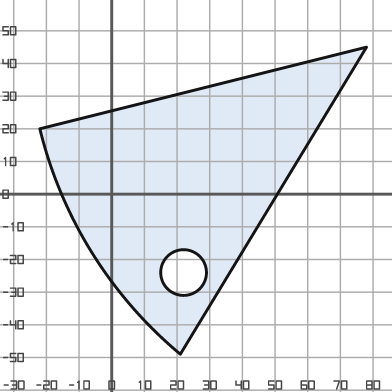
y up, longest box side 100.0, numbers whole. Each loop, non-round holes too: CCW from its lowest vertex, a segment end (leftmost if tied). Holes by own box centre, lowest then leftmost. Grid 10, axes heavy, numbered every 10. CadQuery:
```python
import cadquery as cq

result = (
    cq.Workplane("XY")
    .moveTo(21.0, -49.0)
    .lineTo(78.0, 45.0)
    .lineTo(-22.0, 20.0)
    .threePointArc((-6.0, -18.0), (21.0, -49.0))
    .close()
    .moveTo(22.0, -24.0)
    .circle(7.0)
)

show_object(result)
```